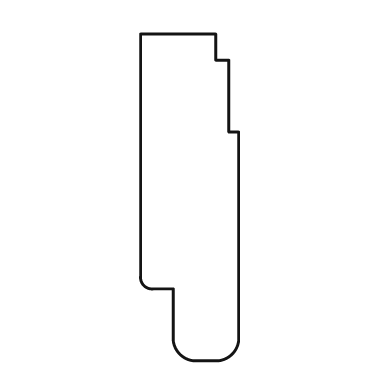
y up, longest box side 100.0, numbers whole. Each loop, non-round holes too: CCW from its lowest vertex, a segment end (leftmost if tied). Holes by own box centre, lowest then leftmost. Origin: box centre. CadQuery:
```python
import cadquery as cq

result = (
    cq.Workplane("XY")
    .moveTo(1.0, -50.0)
    .lineTo(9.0, -50.0)
    .threePointArc((13.0, -48.0), (15.0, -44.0))
    .lineTo(15.0, 20.0)
    .lineTo(12.0, 20.0)
    .lineTo(12.0, 42.0)
    .lineTo(8.0, 42.0)
    .lineTo(8.0, 50.0)
    .lineTo(-15.0, 50.0)
    .lineTo(-15.0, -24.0)
    .threePointArc((-14.0, -27.0), (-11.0, -28.0))
    .lineTo(-5.0, -28.0)
    .lineTo(-5.0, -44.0)
    .threePointArc((-3.0, -48.0), (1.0, -50.0))
    .close()
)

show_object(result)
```